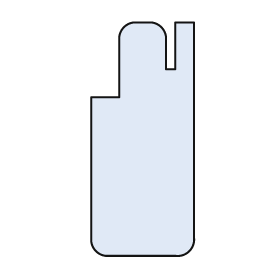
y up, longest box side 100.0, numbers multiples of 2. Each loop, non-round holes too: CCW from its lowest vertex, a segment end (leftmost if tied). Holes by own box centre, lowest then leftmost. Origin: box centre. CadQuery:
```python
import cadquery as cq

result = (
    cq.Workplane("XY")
    .moveTo(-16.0, -50.0)
    .lineTo(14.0, -50.0)
    .threePointArc((20.0, -48.0), (22.0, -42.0))
    .lineTo(22.0, 50.0)
    .lineTo(14.0, 50.0)
    .lineTo(14.0, 30.0)
    .lineTo(10.0, 30.0)
    .lineTo(10.0, 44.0)
    .threePointArc((8.0, 48.0), (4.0, 50.0))
    .lineTo(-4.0, 50.0)
    .threePointArc((-8.0, 48.0), (-10.0, 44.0))
    .lineTo(-10.0, 18.0)
    .lineTo(-22.0, 18.0)
    .lineTo(-22.0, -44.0)
    .threePointArc((-20.0, -48.0), (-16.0, -50.0))
    .close()
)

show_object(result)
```